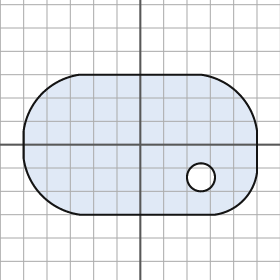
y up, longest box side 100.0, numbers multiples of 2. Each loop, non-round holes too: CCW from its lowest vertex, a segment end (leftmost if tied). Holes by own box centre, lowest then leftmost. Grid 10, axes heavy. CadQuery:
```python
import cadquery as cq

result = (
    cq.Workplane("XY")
    .moveTo(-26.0, -30.0)
    .lineTo(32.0, -30.0)
    .threePointArc((44.0, -24.0), (50.0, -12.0))
    .lineTo(50.0, 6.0)
    .threePointArc((42.0, 22.0), (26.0, 30.0))
    .lineTo(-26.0, 30.0)
    .threePointArc((-42.0, 22.0), (-50.0, 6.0))
    .lineTo(-50.0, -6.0)
    .threePointArc((-42.0, -22.0), (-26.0, -30.0))
    .close()
    .moveTo(26.0, -14.0)
    .circle(6.0)
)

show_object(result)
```